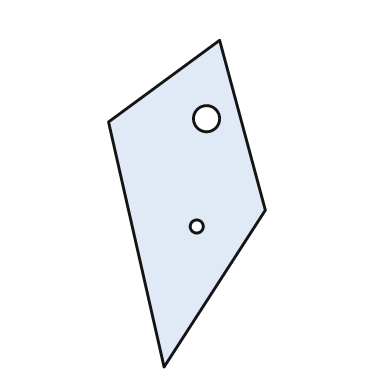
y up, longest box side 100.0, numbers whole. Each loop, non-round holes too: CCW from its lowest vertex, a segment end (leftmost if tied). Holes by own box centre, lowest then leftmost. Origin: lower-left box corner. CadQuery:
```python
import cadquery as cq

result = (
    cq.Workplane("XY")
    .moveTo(17.0, 0.0)
    .lineTo(48.0, 48.0)
    .lineTo(34.0, 100.0)
    .lineTo(0.0, 75.0)
    .close()
    .moveTo(27.0, 43.0)
    .circle(2.0)
    .moveTo(30.0, 76.0)
    .circle(4.0)
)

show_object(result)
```